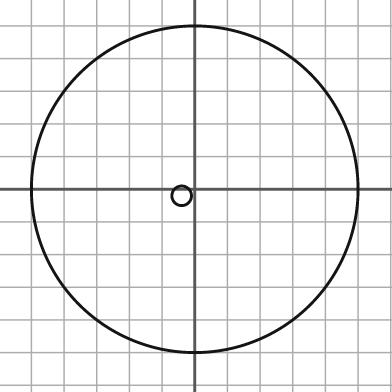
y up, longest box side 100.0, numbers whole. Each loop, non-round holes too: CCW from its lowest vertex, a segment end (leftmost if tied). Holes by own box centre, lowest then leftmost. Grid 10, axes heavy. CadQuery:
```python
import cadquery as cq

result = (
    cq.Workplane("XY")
    .moveTo(0.0, 0.0)
    .circle(50.0)
    .moveTo(-4.0, -2.0)
    .circle(3.0)
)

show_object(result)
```